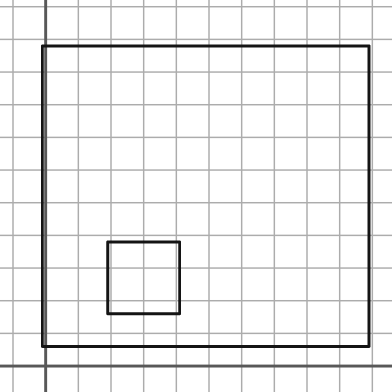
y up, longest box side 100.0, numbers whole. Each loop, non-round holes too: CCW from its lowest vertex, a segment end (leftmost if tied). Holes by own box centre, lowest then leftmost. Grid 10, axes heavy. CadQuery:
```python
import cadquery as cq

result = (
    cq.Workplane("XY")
    .moveTo(-1.0, 6.0)
    .lineTo(99.0, 6.0)
    .lineTo(99.0, 98.0)
    .lineTo(-1.0, 98.0)
    .close()
    .moveTo(19.0, 16.0)
    .lineTo(41.0, 16.0)
    .lineTo(41.0, 38.0)
    .lineTo(19.0, 38.0)
    .close()
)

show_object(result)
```